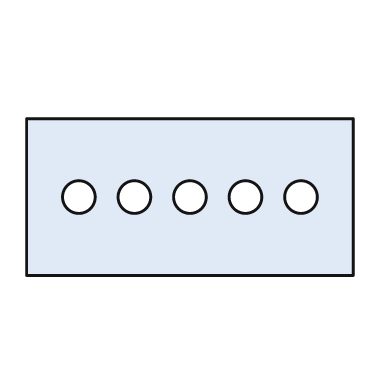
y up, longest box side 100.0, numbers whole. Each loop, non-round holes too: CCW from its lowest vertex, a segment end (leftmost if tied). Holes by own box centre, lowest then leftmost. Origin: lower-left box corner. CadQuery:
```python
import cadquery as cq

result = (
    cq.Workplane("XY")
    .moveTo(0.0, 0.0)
    .lineTo(100.0, 0.0)
    .lineTo(100.0, 48.0)
    .lineTo(0.0, 48.0)
    .close()
    .moveTo(16.0, 24.0)
    .circle(5.0)
    .moveTo(33.0, 24.0)
    .circle(5.0)
    .moveTo(50.0, 24.0)
    .circle(5.0)
    .moveTo(67.0, 24.0)
    .circle(5.0)
    .moveTo(84.0, 24.0)
    .circle(5.0)
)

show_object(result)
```